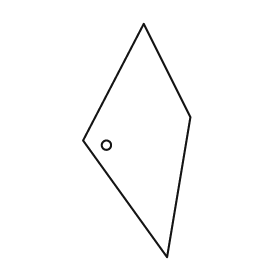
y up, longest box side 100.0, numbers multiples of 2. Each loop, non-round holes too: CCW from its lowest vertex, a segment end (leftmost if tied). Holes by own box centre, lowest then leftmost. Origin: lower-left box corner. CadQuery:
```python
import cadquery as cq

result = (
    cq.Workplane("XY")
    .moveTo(36.0, 0.0)
    .lineTo(46.0, 60.0)
    .lineTo(26.0, 100.0)
    .lineTo(0.0, 50.0)
    .close()
    .moveTo(10.0, 48.0)
    .circle(2.0)
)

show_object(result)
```